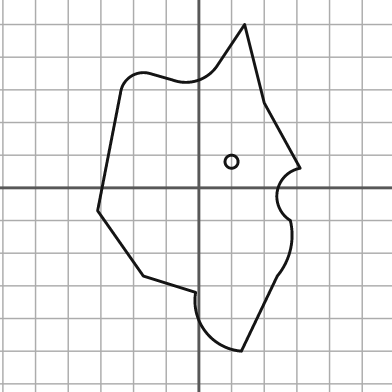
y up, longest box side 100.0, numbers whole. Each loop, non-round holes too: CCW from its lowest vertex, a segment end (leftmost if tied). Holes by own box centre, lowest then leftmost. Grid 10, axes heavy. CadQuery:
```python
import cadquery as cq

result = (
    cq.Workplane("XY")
    .moveTo(13.0, -50.0)
    .lineTo(24.0, -27.0)
    .threePointArc((28.0, -19.0), (28.0, -10.0))
    .threePointArc((24.0, -1.0), (31.0, 6.0))
    .lineTo(20.0, 26.0)
    .lineTo(14.0, 50.0)
    .lineTo(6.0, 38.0)
    .threePointArc((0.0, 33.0), (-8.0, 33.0))
    .lineTo(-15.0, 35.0)
    .threePointArc((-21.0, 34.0), (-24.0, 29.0))
    .lineTo(-31.0, -7.0)
    .lineTo(-17.0, -27.0)
    .lineTo(-1.0, -32.0)
    .threePointArc((2.0, -44.0), (13.0, -50.0))
    .close()
    .moveTo(10.0, 8.0)
    .circle(2.0)
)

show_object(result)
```